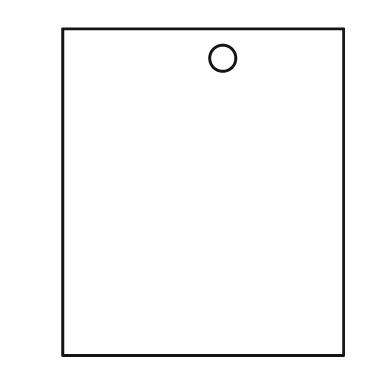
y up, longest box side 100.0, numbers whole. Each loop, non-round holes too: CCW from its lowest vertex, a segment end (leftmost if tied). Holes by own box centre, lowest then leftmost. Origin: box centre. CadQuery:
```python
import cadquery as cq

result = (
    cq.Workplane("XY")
    .moveTo(-43.0, -50.0)
    .lineTo(43.0, -50.0)
    .lineTo(43.0, 50.0)
    .lineTo(-43.0, 50.0)
    .close()
    .moveTo(6.0, 41.0)
    .circle(4.0)
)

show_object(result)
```